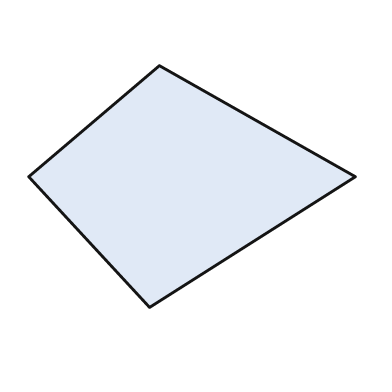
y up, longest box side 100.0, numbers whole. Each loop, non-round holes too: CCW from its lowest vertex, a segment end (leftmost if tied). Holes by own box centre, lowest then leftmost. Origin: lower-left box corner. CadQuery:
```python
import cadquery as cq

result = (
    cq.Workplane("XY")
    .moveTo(37.0, 0.0)
    .lineTo(100.0, 40.0)
    .lineTo(40.0, 74.0)
    .lineTo(0.0, 40.0)
    .close()
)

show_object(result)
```